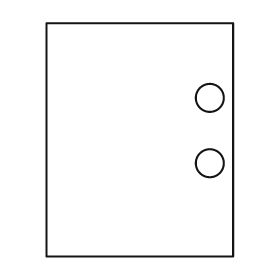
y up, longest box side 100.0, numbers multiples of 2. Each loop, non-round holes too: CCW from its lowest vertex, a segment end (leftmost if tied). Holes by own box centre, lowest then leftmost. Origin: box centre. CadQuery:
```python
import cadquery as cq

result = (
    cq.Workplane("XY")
    .moveTo(-40.0, -50.0)
    .lineTo(40.0, -50.0)
    .lineTo(40.0, 50.0)
    .lineTo(-40.0, 50.0)
    .close()
    .moveTo(30.0, -10.0)
    .circle(6.0)
    .moveTo(30.0, 18.0)
    .circle(6.0)
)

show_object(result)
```